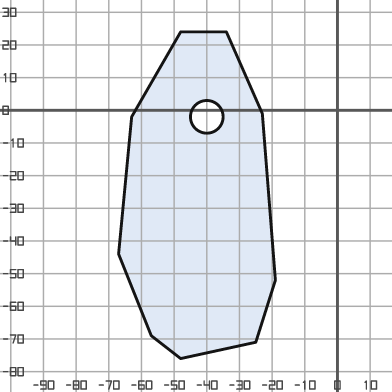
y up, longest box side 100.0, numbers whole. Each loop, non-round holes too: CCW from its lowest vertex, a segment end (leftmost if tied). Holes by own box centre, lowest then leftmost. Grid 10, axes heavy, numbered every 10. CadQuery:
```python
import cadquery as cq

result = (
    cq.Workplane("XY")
    .moveTo(-48.0, -76.0)
    .lineTo(-25.0, -71.0)
    .lineTo(-19.0, -52.0)
    .lineTo(-23.0, -1.0)
    .lineTo(-34.0, 24.0)
    .lineTo(-48.0, 24.0)
    .lineTo(-63.0, -2.0)
    .lineTo(-67.0, -44.0)
    .lineTo(-57.0, -69.0)
    .close()
    .moveTo(-40.0, -2.0)
    .circle(5.0)
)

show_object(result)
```